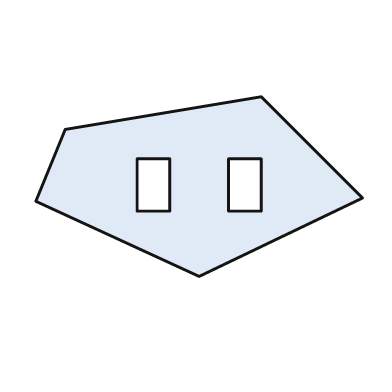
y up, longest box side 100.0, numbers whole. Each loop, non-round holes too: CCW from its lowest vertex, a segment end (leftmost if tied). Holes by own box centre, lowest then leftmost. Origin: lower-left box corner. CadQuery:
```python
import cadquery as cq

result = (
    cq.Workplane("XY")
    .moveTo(50.0, 0.0)
    .lineTo(100.0, 24.0)
    .lineTo(69.0, 55.0)
    .lineTo(9.0, 45.0)
    .lineTo(0.0, 23.0)
    .close()
    .moveTo(31.0, 20.0)
    .lineTo(41.0, 20.0)
    .lineTo(41.0, 36.0)
    .lineTo(31.0, 36.0)
    .close()
    .moveTo(59.0, 20.0)
    .lineTo(69.0, 20.0)
    .lineTo(69.0, 36.0)
    .lineTo(59.0, 36.0)
    .close()
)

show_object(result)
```